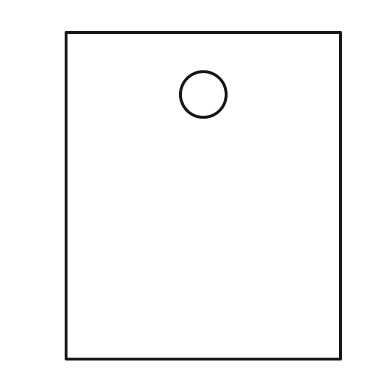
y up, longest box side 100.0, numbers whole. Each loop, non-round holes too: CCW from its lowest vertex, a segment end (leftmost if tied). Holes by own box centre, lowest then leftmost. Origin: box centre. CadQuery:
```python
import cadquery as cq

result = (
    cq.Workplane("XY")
    .moveTo(-42.0, -50.0)
    .lineTo(42.0, -50.0)
    .lineTo(42.0, 50.0)
    .lineTo(-42.0, 50.0)
    .close()
    .moveTo(0.0, 31.0)
    .circle(7.0)
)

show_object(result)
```